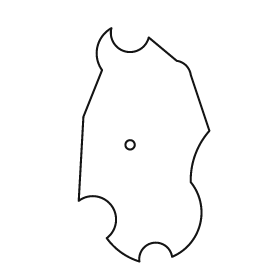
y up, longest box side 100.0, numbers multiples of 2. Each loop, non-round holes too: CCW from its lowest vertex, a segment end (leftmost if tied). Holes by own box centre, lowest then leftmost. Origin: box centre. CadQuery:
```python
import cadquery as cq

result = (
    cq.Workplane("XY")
    .moveTo(-2.0, -50.0)
    .threePointArc((4.0, -42.0), (12.0, -48.0))
    .threePointArc((24.0, -34.0), (20.0, -16.0))
    .threePointArc((22.0, -4.0), (28.0, 6.0))
    .lineTo(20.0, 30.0)
    .threePointArc((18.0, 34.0), (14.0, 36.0))
    .lineTo(2.0, 46.0)
    .threePointArc((-8.0, 40.0), (-14.0, 50.0))
    .threePointArc((-20.0, 42.0), (-18.0, 32.0))
    .lineTo(-26.0, 12.0)
    .lineTo(-28.0, -24.0)
    .threePointArc((-14.0, -26.0), (-16.0, -40.0))
    .threePointArc((-10.0, -46.0), (-2.0, -50.0))
    .close()
    .moveTo(-6.0, 0.0)
    .circle(2.0)
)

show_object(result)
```